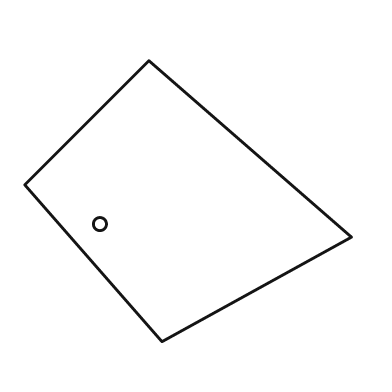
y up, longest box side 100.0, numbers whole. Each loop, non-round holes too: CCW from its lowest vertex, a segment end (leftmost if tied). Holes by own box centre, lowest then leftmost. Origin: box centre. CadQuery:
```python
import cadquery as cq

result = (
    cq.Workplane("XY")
    .moveTo(-8.0, -43.0)
    .lineTo(50.0, -11.0)
    .lineTo(-12.0, 43.0)
    .lineTo(-50.0, 5.0)
    .close()
    .moveTo(-27.0, -7.0)
    .circle(2.0)
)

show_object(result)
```